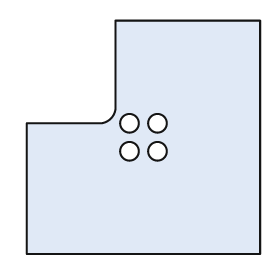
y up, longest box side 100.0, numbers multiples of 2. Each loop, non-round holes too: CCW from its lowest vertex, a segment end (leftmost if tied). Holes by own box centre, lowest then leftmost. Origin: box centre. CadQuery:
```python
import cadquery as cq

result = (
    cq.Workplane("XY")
    .moveTo(-50.0, -50.0)
    .lineTo(50.0, -50.0)
    .lineTo(50.0, 50.0)
    .lineTo(-12.0, 50.0)
    .lineTo(-12.0, 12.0)
    .threePointArc((-14.0, 8.0), (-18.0, 6.0))
    .lineTo(-50.0, 6.0)
    .close()
    .moveTo(-6.0, -6.0)
    .circle(4.0)
    .moveTo(6.0, -6.0)
    .circle(4.0)
    .moveTo(-6.0, 6.0)
    .circle(4.0)
    .moveTo(6.0, 6.0)
    .circle(4.0)
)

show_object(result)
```